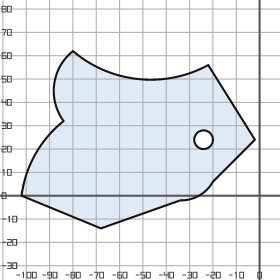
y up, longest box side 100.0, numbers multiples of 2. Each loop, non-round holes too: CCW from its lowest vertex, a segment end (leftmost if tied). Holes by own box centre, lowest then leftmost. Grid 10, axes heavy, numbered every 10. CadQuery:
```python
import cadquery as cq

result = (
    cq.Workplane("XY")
    .moveTo(-68.0, -14.0)
    .lineTo(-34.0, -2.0)
    .threePointArc((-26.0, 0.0), (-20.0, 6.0))
    .lineTo(-2.0, 24.0)
    .lineTo(-22.0, 56.0)
    .threePointArc((-52.0, 50.0), (-80.0, 62.0))
    .threePointArc((-88.0, 48.0), (-84.0, 32.0))
    .threePointArc((-96.0, 18.0), (-102.0, 0.0))
    .close()
    .moveTo(-24.0, 24.0)
    .circle(4.0)
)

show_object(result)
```